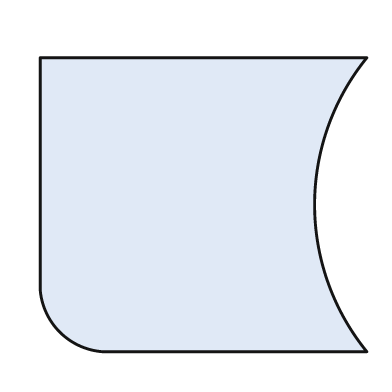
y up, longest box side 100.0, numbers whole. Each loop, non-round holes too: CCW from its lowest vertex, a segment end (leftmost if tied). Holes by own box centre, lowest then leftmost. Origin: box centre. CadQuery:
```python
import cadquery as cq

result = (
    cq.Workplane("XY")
    .moveTo(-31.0, -45.0)
    .lineTo(50.0, -45.0)
    .threePointArc((34.0, 0.0), (50.0, 45.0))
    .lineTo(-50.0, 45.0)
    .lineTo(-50.0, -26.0)
    .threePointArc((-44.0, -39.0), (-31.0, -45.0))
    .close()
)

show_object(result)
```